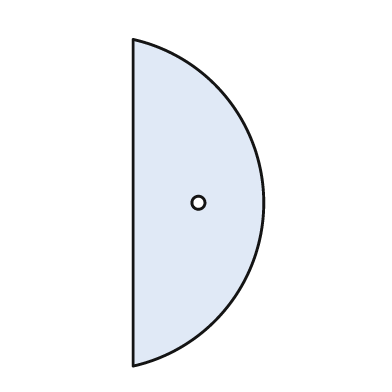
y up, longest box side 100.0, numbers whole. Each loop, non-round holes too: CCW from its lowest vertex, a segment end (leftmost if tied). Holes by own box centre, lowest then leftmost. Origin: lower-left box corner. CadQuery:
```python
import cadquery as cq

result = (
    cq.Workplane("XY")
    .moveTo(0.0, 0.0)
    .threePointArc((40.0, 50.0), (0.0, 100.0))
    .close()
    .moveTo(20.0, 50.0)
    .circle(2.0)
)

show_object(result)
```